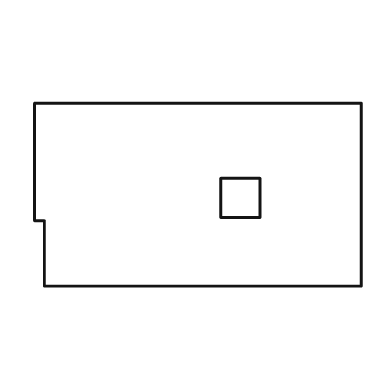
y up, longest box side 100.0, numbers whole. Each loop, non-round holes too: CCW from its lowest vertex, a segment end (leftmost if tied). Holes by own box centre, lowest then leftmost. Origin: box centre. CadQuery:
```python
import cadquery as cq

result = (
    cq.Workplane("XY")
    .moveTo(-47.0, -28.0)
    .lineTo(50.0, -28.0)
    .lineTo(50.0, 28.0)
    .lineTo(-50.0, 28.0)
    .lineTo(-50.0, -8.0)
    .lineTo(-47.0, -8.0)
    .close()
    .moveTo(7.0, -7.0)
    .lineTo(19.0, -7.0)
    .lineTo(19.0, 5.0)
    .lineTo(7.0, 5.0)
    .close()
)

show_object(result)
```